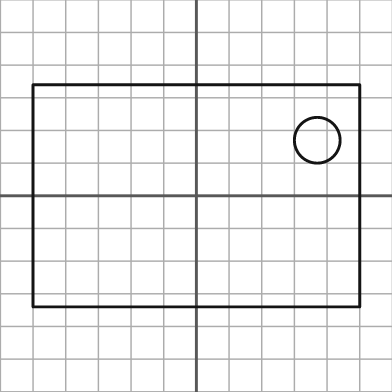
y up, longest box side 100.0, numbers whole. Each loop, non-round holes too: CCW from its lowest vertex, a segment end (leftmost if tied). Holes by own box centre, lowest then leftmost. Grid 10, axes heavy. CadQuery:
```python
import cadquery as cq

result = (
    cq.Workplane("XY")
    .moveTo(-50.0, -34.0)
    .lineTo(50.0, -34.0)
    .lineTo(50.0, 34.0)
    .lineTo(-50.0, 34.0)
    .close()
    .moveTo(37.0, 17.0)
    .circle(7.0)
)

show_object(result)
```